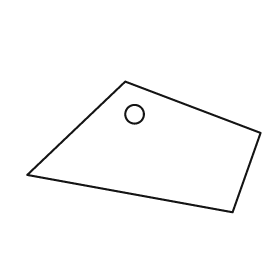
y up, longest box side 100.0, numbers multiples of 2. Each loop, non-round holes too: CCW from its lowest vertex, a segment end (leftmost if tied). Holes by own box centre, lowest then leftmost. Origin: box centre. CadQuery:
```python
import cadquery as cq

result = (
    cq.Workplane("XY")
    .moveTo(38.0, -28.0)
    .lineTo(50.0, 6.0)
    .lineTo(-8.0, 28.0)
    .lineTo(-50.0, -12.0)
    .close()
    .moveTo(-4.0, 14.0)
    .circle(4.0)
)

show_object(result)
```